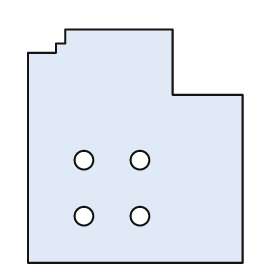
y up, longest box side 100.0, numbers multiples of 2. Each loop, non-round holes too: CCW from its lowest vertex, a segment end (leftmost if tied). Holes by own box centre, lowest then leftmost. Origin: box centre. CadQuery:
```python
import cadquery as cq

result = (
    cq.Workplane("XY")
    .moveTo(-46.0, -50.0)
    .lineTo(46.0, -50.0)
    .lineTo(46.0, 22.0)
    .lineTo(16.0, 22.0)
    .lineTo(16.0, 50.0)
    .lineTo(-30.0, 50.0)
    .lineTo(-30.0, 44.0)
    .lineTo(-34.0, 44.0)
    .lineTo(-34.0, 40.0)
    .lineTo(-46.0, 40.0)
    .close()
    .moveTo(-22.0, -30.0)
    .circle(4.0)
    .moveTo(2.0, -30.0)
    .circle(4.0)
    .moveTo(-22.0, -6.0)
    .circle(4.0)
    .moveTo(2.0, -6.0)
    .circle(4.0)
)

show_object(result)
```